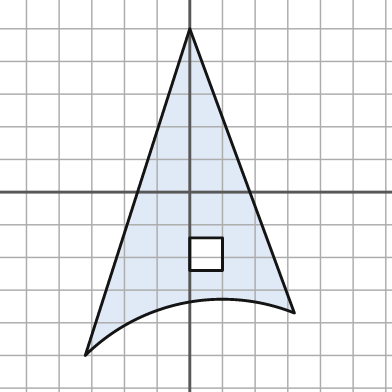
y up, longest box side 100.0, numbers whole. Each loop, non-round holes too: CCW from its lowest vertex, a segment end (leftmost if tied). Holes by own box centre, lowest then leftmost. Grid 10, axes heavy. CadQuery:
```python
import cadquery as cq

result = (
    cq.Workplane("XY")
    .moveTo(-32.0, -50.0)
    .threePointArc((-2.0, -34.0), (32.0, -37.0))
    .lineTo(0.0, 50.0)
    .close()
    .moveTo(0.0, -24.0)
    .lineTo(10.0, -24.0)
    .lineTo(10.0, -14.0)
    .lineTo(0.0, -14.0)
    .close()
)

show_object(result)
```